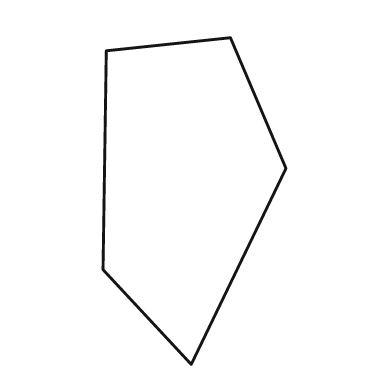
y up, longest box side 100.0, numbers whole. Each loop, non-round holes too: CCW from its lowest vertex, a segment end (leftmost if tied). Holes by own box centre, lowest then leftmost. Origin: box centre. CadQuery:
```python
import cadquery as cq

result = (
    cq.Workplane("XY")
    .moveTo(-1.0, -50.0)
    .lineTo(28.0, 10.0)
    .lineTo(11.0, 50.0)
    .lineTo(-27.0, 46.0)
    .lineTo(-28.0, -21.0)
    .close()
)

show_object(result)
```